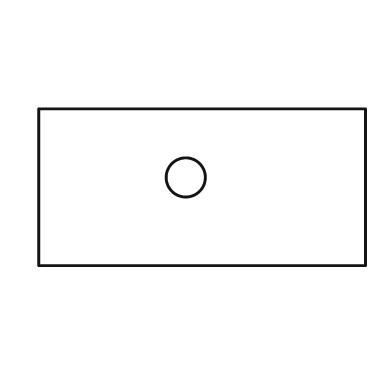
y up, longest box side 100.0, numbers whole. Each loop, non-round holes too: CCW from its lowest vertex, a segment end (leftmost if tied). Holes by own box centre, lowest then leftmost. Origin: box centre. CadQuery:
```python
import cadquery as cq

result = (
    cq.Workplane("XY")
    .moveTo(-50.0, -24.0)
    .lineTo(50.0, -24.0)
    .lineTo(50.0, 24.0)
    .lineTo(-50.0, 24.0)
    .close()
    .moveTo(-5.0, 3.0)
    .circle(6.0)
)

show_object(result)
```